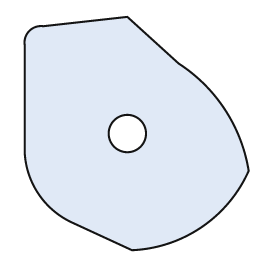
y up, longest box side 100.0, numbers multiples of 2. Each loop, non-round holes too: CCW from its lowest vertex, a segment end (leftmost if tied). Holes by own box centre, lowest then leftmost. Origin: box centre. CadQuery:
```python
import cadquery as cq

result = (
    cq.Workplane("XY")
    .moveTo(-2.0, -50.0)
    .threePointArc((28.0, -40.0), (48.0, -16.0))
    .threePointArc((38.0, 10.0), (18.0, 30.0))
    .lineTo(-4.0, 50.0)
    .lineTo(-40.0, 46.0)
    .threePointArc((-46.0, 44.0), (-48.0, 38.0))
    .lineTo(-48.0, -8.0)
    .threePointArc((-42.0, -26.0), (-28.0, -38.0))
    .close()
    .moveTo(-4.0, 0.0)
    .circle(8.0)
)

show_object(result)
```